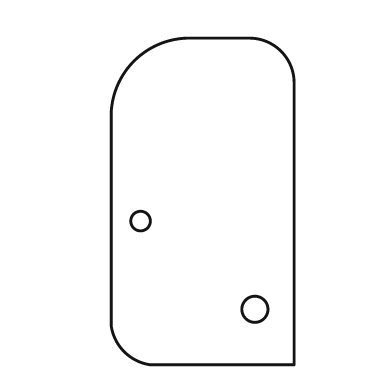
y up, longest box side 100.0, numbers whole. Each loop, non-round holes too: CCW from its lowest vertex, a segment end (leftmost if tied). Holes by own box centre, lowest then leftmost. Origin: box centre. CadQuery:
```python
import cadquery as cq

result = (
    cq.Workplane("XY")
    .moveTo(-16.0, -50.0)
    .lineTo(28.0, -50.0)
    .lineTo(28.0, 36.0)
    .threePointArc((24.0, 46.0), (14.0, 50.0))
    .lineTo(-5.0, 50.0)
    .threePointArc((-21.0, 43.0), (-28.0, 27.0))
    .lineTo(-28.0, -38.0)
    .threePointArc((-24.0, -46.0), (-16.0, -50.0))
    .close()
    .moveTo(16.0, -33.0)
    .circle(4.0)
    .moveTo(-19.0, -6.0)
    .circle(3.0)
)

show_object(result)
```